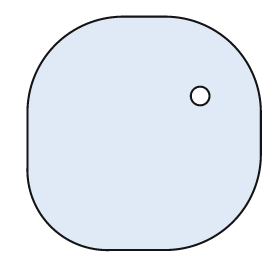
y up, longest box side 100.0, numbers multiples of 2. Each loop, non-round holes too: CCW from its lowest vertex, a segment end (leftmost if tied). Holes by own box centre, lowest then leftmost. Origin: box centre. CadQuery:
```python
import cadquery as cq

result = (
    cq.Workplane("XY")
    .moveTo(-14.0, -50.0)
    .lineTo(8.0, -50.0)
    .threePointArc((38.0, -38.0), (50.0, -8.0))
    .lineTo(50.0, 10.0)
    .threePointArc((38.0, 38.0), (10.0, 50.0))
    .lineTo(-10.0, 50.0)
    .threePointArc((-38.0, 38.0), (-50.0, 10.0))
    .lineTo(-50.0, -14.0)
    .threePointArc((-40.0, -40.0), (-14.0, -50.0))
    .close()
    .moveTo(24.0, 16.0)
    .circle(4.0)
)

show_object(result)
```